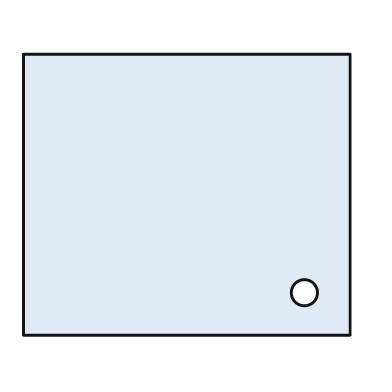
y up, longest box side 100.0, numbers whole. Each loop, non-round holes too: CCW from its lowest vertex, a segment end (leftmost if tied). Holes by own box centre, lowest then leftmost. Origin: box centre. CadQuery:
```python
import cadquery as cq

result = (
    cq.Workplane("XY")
    .moveTo(-50.0, -43.0)
    .lineTo(50.0, -43.0)
    .lineTo(50.0, 43.0)
    .lineTo(-50.0, 43.0)
    .close()
    .moveTo(36.0, -30.0)
    .circle(4.0)
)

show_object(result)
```